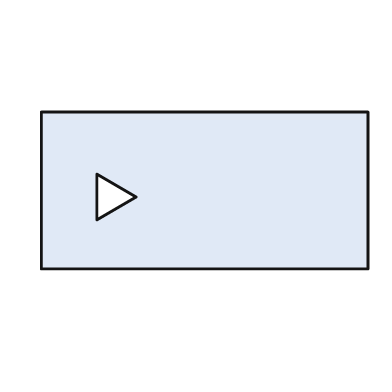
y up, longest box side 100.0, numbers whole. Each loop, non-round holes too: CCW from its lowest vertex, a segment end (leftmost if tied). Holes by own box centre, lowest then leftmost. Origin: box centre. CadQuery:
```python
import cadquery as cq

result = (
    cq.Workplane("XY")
    .moveTo(-50.0, -24.0)
    .lineTo(50.0, -24.0)
    .lineTo(50.0, 24.0)
    .lineTo(-50.0, 24.0)
    .close()
    .moveTo(-33.0, -9.0)
    .lineTo(-21.0, -2.0)
    .lineTo(-33.0, 5.0)
    .close()
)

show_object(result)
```